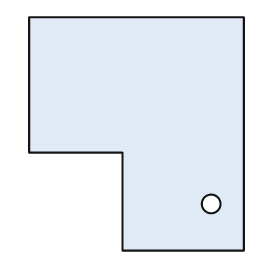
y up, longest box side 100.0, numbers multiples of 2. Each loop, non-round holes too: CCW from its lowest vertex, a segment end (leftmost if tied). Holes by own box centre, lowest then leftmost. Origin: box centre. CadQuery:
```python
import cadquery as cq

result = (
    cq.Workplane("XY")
    .moveTo(-6.0, -50.0)
    .lineTo(46.0, -50.0)
    .lineTo(46.0, 50.0)
    .lineTo(-46.0, 50.0)
    .lineTo(-46.0, -8.0)
    .lineTo(-6.0, -8.0)
    .close()
    .moveTo(32.0, -30.0)
    .circle(4.0)
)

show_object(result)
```